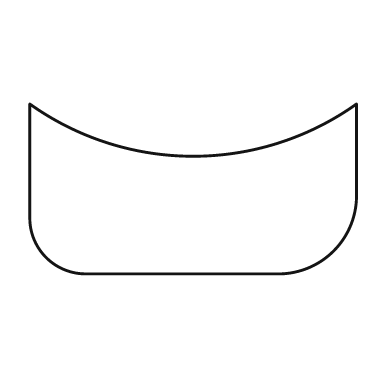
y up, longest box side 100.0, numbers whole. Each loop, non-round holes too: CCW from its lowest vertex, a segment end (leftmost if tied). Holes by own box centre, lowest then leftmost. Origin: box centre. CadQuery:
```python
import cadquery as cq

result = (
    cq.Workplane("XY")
    .moveTo(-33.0, -26.0)
    .lineTo(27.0, -26.0)
    .threePointArc((43.0, -19.0), (50.0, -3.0))
    .lineTo(50.0, 26.0)
    .threePointArc((0.0, 10.0), (-50.0, 26.0))
    .lineTo(-50.0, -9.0)
    .threePointArc((-45.0, -21.0), (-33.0, -26.0))
    .close()
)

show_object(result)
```